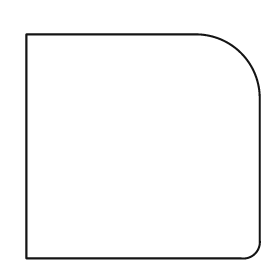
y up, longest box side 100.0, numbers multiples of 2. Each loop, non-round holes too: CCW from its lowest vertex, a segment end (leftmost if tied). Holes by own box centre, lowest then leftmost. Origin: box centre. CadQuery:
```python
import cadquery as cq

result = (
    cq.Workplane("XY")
    .moveTo(-50.0, -48.0)
    .lineTo(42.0, -48.0)
    .threePointArc((48.0, -46.0), (50.0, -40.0))
    .lineTo(50.0, 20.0)
    .threePointArc((42.0, 40.0), (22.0, 48.0))
    .lineTo(-50.0, 48.0)
    .close()
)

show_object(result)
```